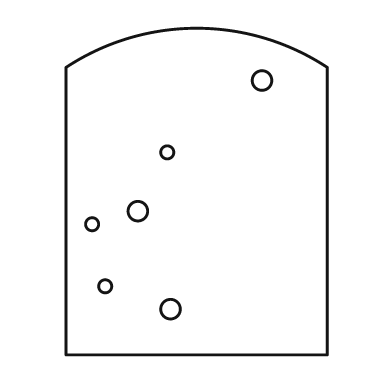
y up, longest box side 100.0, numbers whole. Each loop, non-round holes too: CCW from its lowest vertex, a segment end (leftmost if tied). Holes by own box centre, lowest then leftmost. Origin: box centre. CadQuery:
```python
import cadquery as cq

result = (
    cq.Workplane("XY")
    .moveTo(-40.0, -50.0)
    .lineTo(40.0, -50.0)
    .lineTo(40.0, 38.0)
    .threePointArc((0.0, 50.0), (-40.0, 38.0))
    .close()
    .moveTo(-8.0, -36.0)
    .circle(3.0)
    .moveTo(-28.0, -29.0)
    .circle(2.0)
    .moveTo(-32.0, -10.0)
    .circle(2.0)
    .moveTo(-18.0, -6.0)
    .circle(3.0)
    .moveTo(-9.0, 12.0)
    .circle(2.0)
    .moveTo(20.0, 34.0)
    .circle(3.0)
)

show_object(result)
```